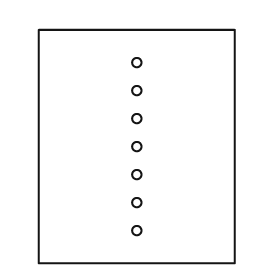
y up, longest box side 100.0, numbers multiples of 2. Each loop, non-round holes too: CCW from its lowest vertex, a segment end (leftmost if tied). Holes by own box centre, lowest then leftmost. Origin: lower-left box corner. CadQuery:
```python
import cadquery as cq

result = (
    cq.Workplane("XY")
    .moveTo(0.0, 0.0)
    .lineTo(84.0, 0.0)
    .lineTo(84.0, 100.0)
    .lineTo(0.0, 100.0)
    .close()
    .moveTo(42.0, 14.0)
    .circle(2.0)
    .moveTo(42.0, 26.0)
    .circle(2.0)
    .moveTo(42.0, 38.0)
    .circle(2.0)
    .moveTo(42.0, 50.0)
    .circle(2.0)
    .moveTo(42.0, 62.0)
    .circle(2.0)
    .moveTo(42.0, 74.0)
    .circle(2.0)
    .moveTo(42.0, 86.0)
    .circle(2.0)
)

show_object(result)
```